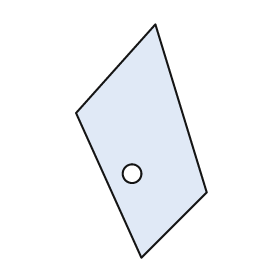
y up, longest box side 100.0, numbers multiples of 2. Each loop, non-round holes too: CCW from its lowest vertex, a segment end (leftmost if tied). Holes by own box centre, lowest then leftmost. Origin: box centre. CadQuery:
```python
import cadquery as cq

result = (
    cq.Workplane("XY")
    .moveTo(0.0, -50.0)
    .lineTo(28.0, -22.0)
    .lineTo(6.0, 50.0)
    .lineTo(-28.0, 12.0)
    .close()
    .moveTo(-4.0, -14.0)
    .circle(4.0)
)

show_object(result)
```